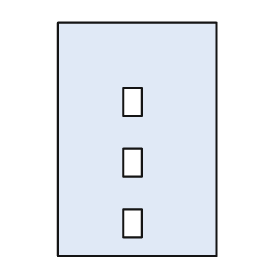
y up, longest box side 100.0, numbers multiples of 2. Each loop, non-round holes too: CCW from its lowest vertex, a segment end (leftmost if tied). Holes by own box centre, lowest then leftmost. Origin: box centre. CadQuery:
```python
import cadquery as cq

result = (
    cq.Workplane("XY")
    .moveTo(-34.0, -50.0)
    .lineTo(34.0, -50.0)
    .lineTo(34.0, 50.0)
    .lineTo(-34.0, 50.0)
    .close()
    .moveTo(-6.0, -42.0)
    .lineTo(2.0, -42.0)
    .lineTo(2.0, -30.0)
    .lineTo(-6.0, -30.0)
    .close()
    .moveTo(-6.0, -16.0)
    .lineTo(2.0, -16.0)
    .lineTo(2.0, -4.0)
    .lineTo(-6.0, -4.0)
    .close()
    .moveTo(-6.0, 10.0)
    .lineTo(2.0, 10.0)
    .lineTo(2.0, 22.0)
    .lineTo(-6.0, 22.0)
    .close()
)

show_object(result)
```